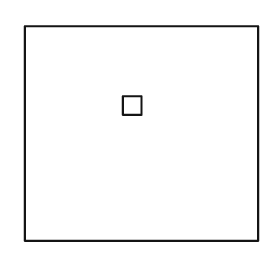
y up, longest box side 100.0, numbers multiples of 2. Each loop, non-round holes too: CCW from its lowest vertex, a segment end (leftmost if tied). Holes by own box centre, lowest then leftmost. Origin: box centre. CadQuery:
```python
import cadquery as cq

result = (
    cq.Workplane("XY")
    .moveTo(-50.0, -46.0)
    .lineTo(50.0, -46.0)
    .lineTo(50.0, 46.0)
    .lineTo(-50.0, 46.0)
    .close()
    .moveTo(-8.0, 8.0)
    .lineTo(0.0, 8.0)
    .lineTo(0.0, 16.0)
    .lineTo(-8.0, 16.0)
    .close()
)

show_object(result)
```